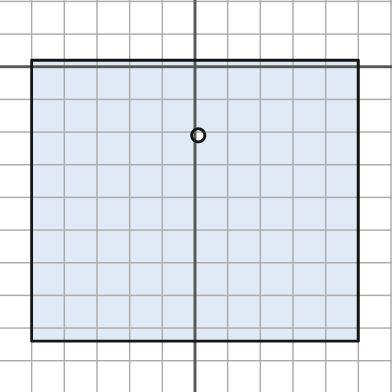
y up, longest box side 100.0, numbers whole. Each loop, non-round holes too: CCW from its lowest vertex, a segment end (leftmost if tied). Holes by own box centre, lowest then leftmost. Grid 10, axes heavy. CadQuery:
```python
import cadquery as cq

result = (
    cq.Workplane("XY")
    .moveTo(-50.0, -84.0)
    .lineTo(50.0, -84.0)
    .lineTo(50.0, 2.0)
    .lineTo(-50.0, 2.0)
    .close()
    .moveTo(1.0, -21.0)
    .circle(2.0)
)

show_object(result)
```